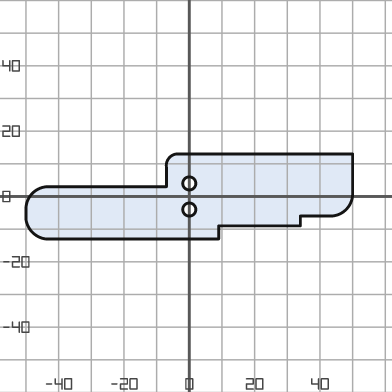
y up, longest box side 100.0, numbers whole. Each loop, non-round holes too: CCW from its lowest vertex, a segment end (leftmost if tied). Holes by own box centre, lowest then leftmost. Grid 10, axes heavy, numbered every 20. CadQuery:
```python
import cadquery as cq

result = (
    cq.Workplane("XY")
    .moveTo(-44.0, -13.0)
    .lineTo(9.0, -13.0)
    .lineTo(9.0, -9.0)
    .lineTo(34.0, -9.0)
    .lineTo(34.0, -6.0)
    .lineTo(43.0, -6.0)
    .threePointArc((48.0, -4.0), (50.0, 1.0))
    .lineTo(50.0, 13.0)
    .lineTo(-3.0, 13.0)
    .threePointArc((-6.0, 12.0), (-7.0, 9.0))
    .lineTo(-7.0, 3.0)
    .lineTo(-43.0, 3.0)
    .threePointArc((-48.0, 1.0), (-50.0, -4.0))
    .lineTo(-50.0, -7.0)
    .threePointArc((-48.0, -11.0), (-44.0, -13.0))
    .close()
    .moveTo(0.0, -4.0)
    .circle(2.0)
    .moveTo(0.0, 4.0)
    .circle(2.0)
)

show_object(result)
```